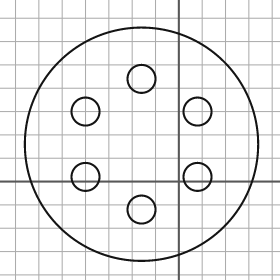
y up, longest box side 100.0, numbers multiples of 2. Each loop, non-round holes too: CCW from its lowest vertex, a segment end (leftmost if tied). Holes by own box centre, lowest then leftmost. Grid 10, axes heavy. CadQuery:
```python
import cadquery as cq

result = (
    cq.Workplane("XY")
    .moveTo(-16.0, 16.0)
    .circle(50.0)
    .moveTo(-16.0, -12.0)
    .circle(6.0)
    .moveTo(-40.0, 2.0)
    .circle(6.0)
    .moveTo(8.0, 2.0)
    .circle(6.0)
    .moveTo(-40.0, 30.0)
    .circle(6.0)
    .moveTo(8.0, 30.0)
    .circle(6.0)
    .moveTo(-16.0, 44.0)
    .circle(6.0)
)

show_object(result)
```